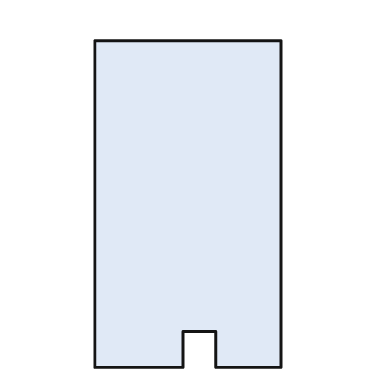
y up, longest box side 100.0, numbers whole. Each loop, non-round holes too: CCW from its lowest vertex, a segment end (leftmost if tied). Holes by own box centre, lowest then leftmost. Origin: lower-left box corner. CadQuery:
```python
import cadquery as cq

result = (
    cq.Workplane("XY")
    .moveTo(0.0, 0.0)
    .lineTo(27.0, 0.0)
    .lineTo(27.0, 11.0)
    .lineTo(37.0, 11.0)
    .lineTo(37.0, 0.0)
    .lineTo(57.0, 0.0)
    .lineTo(57.0, 100.0)
    .lineTo(0.0, 100.0)
    .close()
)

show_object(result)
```